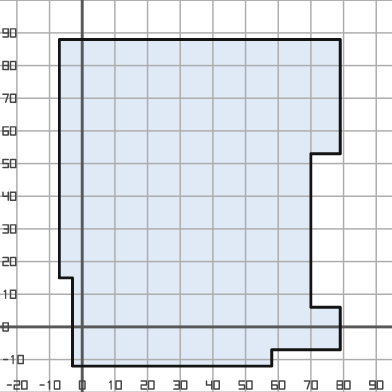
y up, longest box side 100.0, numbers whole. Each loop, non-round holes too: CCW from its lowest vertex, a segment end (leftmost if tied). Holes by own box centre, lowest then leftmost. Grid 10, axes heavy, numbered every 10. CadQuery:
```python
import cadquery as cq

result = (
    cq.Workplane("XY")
    .moveTo(-3.0, -12.0)
    .lineTo(58.0, -12.0)
    .lineTo(58.0, -7.0)
    .lineTo(79.0, -7.0)
    .lineTo(79.0, 6.0)
    .lineTo(70.0, 6.0)
    .lineTo(70.0, 53.0)
    .lineTo(79.0, 53.0)
    .lineTo(79.0, 88.0)
    .lineTo(-7.0, 88.0)
    .lineTo(-7.0, 15.0)
    .lineTo(-3.0, 15.0)
    .close()
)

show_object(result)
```